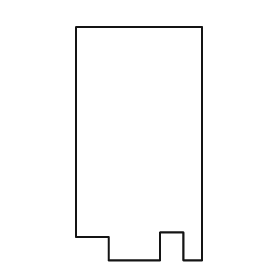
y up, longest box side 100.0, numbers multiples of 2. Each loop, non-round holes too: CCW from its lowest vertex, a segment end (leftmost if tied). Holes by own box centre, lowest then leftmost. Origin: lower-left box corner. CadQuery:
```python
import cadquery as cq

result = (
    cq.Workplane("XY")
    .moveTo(14.0, 0.0)
    .lineTo(36.0, 0.0)
    .lineTo(36.0, 12.0)
    .lineTo(46.0, 12.0)
    .lineTo(46.0, 0.0)
    .lineTo(54.0, 0.0)
    .lineTo(54.0, 100.0)
    .lineTo(0.0, 100.0)
    .lineTo(0.0, 10.0)
    .lineTo(14.0, 10.0)
    .close()
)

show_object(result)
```